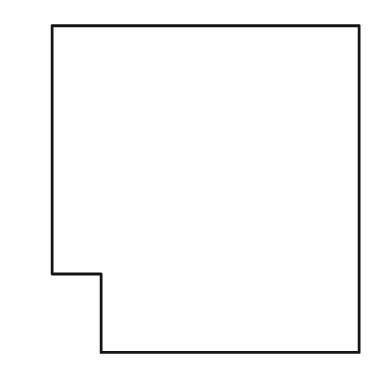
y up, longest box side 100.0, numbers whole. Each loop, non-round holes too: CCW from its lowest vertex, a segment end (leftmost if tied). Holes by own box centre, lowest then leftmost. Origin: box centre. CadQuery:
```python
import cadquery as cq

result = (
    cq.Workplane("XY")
    .moveTo(-32.0, -50.0)
    .lineTo(47.0, -50.0)
    .lineTo(47.0, 50.0)
    .lineTo(-47.0, 50.0)
    .lineTo(-47.0, -26.0)
    .lineTo(-32.0, -26.0)
    .close()
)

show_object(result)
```